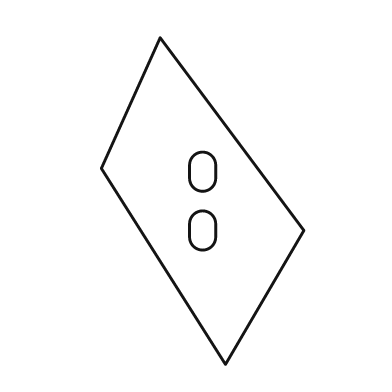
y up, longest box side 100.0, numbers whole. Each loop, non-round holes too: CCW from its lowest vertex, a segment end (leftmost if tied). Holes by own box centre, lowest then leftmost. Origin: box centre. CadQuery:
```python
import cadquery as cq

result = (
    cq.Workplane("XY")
    .moveTo(7.0, -50.0)
    .lineTo(31.0, -9.0)
    .lineTo(-13.0, 50.0)
    .lineTo(-31.0, 10.0)
    .close()
    .moveTo(-4.0, -11.0)
    .threePointArc((0.0, -15.0), (4.0, -11.0))
    .lineTo(4.0, -7.0)
    .threePointArc((0.0, -3.0), (-4.0, -7.0))
    .close()
    .moveTo(-4.0, 7.0)
    .threePointArc((0.0, 3.0), (4.0, 7.0))
    .lineTo(4.0, 11.0)
    .threePointArc((0.0, 15.0), (-4.0, 11.0))
    .close()
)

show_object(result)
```